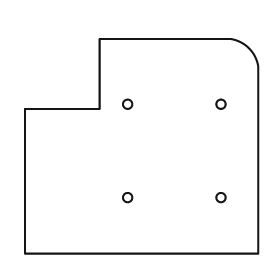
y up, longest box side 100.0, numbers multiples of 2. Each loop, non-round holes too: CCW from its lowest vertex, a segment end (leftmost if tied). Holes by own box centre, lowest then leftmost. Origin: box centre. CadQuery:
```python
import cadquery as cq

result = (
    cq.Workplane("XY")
    .moveTo(-50.0, -46.0)
    .lineTo(50.0, -46.0)
    .lineTo(50.0, 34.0)
    .threePointArc((46.0, 42.0), (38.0, 46.0))
    .lineTo(-18.0, 46.0)
    .lineTo(-18.0, 16.0)
    .lineTo(-50.0, 16.0)
    .close()
    .moveTo(-6.0, -22.0)
    .circle(2.0)
    .moveTo(34.0, -22.0)
    .circle(2.0)
    .moveTo(-6.0, 18.0)
    .circle(2.0)
    .moveTo(34.0, 18.0)
    .circle(2.0)
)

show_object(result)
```